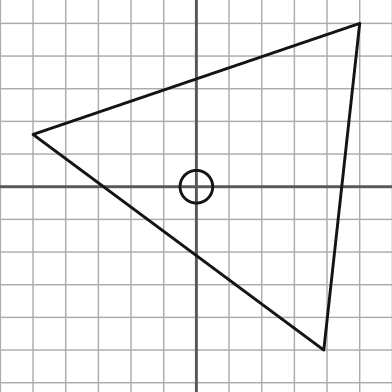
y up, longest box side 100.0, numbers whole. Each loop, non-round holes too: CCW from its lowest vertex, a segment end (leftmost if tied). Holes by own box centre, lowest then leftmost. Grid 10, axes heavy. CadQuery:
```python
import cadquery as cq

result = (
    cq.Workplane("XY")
    .moveTo(39.0, -50.0)
    .lineTo(50.0, 50.0)
    .lineTo(-50.0, 16.0)
    .close()
    .moveTo(0.0, 0.0)
    .circle(5.0)
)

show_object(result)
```